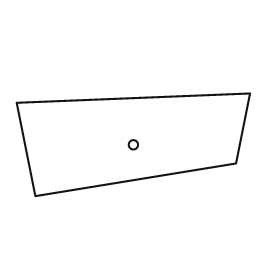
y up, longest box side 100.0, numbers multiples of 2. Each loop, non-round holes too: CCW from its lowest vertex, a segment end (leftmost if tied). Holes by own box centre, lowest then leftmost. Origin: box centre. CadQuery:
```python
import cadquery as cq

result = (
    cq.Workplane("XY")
    .moveTo(-42.0, -22.0)
    .lineTo(44.0, -8.0)
    .lineTo(50.0, 22.0)
    .lineTo(-50.0, 18.0)
    .close()
    .moveTo(0.0, 0.0)
    .circle(2.0)
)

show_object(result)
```